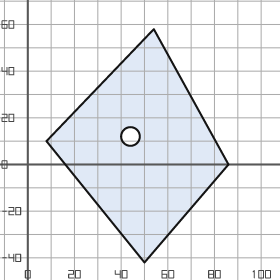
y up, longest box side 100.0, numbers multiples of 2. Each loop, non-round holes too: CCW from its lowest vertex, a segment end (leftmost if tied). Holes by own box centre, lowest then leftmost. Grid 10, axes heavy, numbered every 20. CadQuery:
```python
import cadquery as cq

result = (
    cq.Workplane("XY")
    .moveTo(50.0, -42.0)
    .lineTo(86.0, 0.0)
    .lineTo(54.0, 58.0)
    .lineTo(8.0, 10.0)
    .close()
    .moveTo(44.0, 12.0)
    .circle(4.0)
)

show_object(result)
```